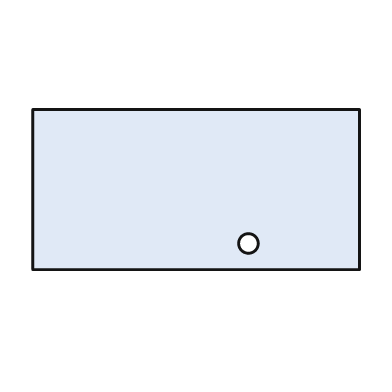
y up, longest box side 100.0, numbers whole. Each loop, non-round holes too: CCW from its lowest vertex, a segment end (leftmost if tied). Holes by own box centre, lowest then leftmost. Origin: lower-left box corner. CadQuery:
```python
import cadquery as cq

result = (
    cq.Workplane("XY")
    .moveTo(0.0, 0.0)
    .lineTo(100.0, 0.0)
    .lineTo(100.0, 49.0)
    .lineTo(0.0, 49.0)
    .close()
    .moveTo(66.0, 8.0)
    .circle(3.0)
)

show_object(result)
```